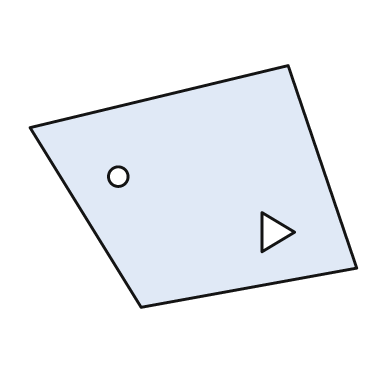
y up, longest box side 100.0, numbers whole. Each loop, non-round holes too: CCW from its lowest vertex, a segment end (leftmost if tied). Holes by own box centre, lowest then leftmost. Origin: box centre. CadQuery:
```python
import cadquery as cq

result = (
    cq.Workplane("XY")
    .moveTo(-16.0, -37.0)
    .lineTo(50.0, -25.0)
    .lineTo(29.0, 37.0)
    .lineTo(-50.0, 18.0)
    .close()
    .moveTo(21.0, -20.0)
    .lineTo(31.0, -14.0)
    .lineTo(21.0, -8.0)
    .close()
    .moveTo(-23.0, 3.0)
    .circle(3.0)
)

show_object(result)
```